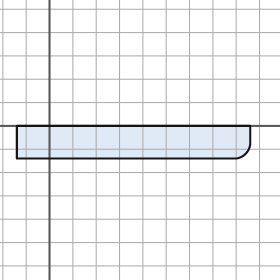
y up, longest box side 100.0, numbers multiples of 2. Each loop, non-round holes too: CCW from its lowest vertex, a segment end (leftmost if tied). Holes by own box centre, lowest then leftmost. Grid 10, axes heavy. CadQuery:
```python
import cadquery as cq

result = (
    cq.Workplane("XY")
    .moveTo(-14.0, -14.0)
    .lineTo(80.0, -14.0)
    .threePointArc((84.0, -12.0), (86.0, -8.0))
    .lineTo(86.0, 0.0)
    .lineTo(-14.0, 0.0)
    .close()
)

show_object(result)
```